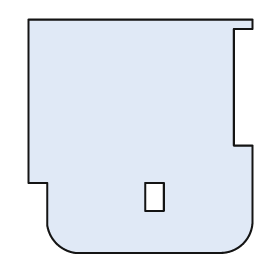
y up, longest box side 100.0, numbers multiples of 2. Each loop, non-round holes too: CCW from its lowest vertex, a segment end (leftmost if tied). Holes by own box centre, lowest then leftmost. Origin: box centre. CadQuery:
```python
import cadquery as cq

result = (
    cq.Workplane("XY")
    .moveTo(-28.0, -50.0)
    .lineTo(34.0, -50.0)
    .threePointArc((44.0, -46.0), (48.0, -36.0))
    .lineTo(48.0, -4.0)
    .lineTo(40.0, -4.0)
    .lineTo(40.0, 46.0)
    .lineTo(48.0, 46.0)
    .lineTo(48.0, 50.0)
    .lineTo(-48.0, 50.0)
    .lineTo(-48.0, -20.0)
    .lineTo(-40.0, -20.0)
    .lineTo(-40.0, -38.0)
    .threePointArc((-36.0, -46.0), (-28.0, -50.0))
    .close()
    .moveTo(2.0, -32.0)
    .lineTo(10.0, -32.0)
    .lineTo(10.0, -20.0)
    .lineTo(2.0, -20.0)
    .close()
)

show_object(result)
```